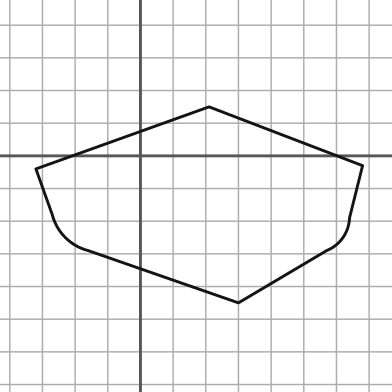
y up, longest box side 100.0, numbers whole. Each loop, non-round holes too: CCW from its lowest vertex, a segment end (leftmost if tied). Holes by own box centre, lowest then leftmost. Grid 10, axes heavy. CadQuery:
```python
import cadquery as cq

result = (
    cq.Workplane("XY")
    .moveTo(30.0, -45.0)
    .lineTo(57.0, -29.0)
    .threePointArc((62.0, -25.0), (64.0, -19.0))
    .lineTo(68.0, -3.0)
    .lineTo(21.0, 15.0)
    .lineTo(-32.0, -4.0)
    .lineTo(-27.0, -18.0)
    .threePointArc((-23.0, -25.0), (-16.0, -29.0))
    .close()
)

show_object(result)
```